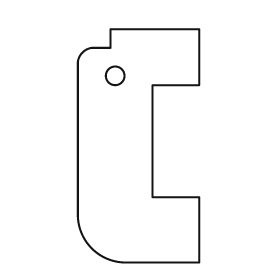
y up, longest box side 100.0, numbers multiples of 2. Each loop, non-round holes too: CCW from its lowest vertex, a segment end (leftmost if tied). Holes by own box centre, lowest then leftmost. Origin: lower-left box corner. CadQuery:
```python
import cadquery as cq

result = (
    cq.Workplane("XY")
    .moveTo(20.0, 0.0)
    .lineTo(52.0, 0.0)
    .lineTo(52.0, 28.0)
    .lineTo(32.0, 28.0)
    .lineTo(32.0, 76.0)
    .lineTo(52.0, 76.0)
    .lineTo(52.0, 100.0)
    .lineTo(14.0, 100.0)
    .lineTo(14.0, 92.0)
    .lineTo(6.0, 92.0)
    .threePointArc((2.0, 90.0), (0.0, 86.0))
    .lineTo(0.0, 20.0)
    .threePointArc((6.0, 6.0), (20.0, 0.0))
    .close()
    .moveTo(16.0, 80.0)
    .circle(4.0)
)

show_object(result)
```